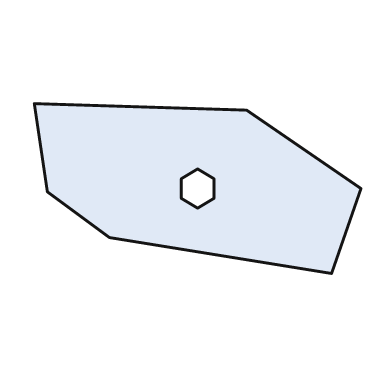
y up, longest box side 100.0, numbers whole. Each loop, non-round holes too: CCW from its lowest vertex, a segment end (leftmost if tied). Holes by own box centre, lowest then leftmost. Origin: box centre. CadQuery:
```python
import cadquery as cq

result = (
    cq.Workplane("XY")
    .moveTo(41.0, -26.0)
    .lineTo(50.0, 0.0)
    .lineTo(15.0, 24.0)
    .lineTo(-50.0, 26.0)
    .lineTo(-46.0, -1.0)
    .lineTo(-27.0, -15.0)
    .close()
    .moveTo(0.0, -6.0)
    .lineTo(5.0, -3.0)
    .lineTo(5.0, 3.0)
    .lineTo(0.0, 6.0)
    .lineTo(-5.0, 3.0)
    .lineTo(-5.0, -3.0)
    .close()
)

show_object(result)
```